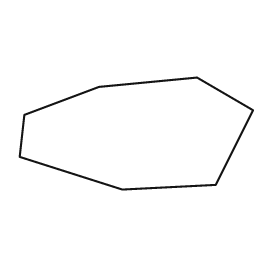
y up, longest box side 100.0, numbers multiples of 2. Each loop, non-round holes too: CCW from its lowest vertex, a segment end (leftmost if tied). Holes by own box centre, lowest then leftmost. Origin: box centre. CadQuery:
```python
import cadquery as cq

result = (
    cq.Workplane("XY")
    .moveTo(-6.0, -24.0)
    .lineTo(34.0, -22.0)
    .lineTo(50.0, 10.0)
    .lineTo(26.0, 24.0)
    .lineTo(-16.0, 20.0)
    .lineTo(-48.0, 8.0)
    .lineTo(-50.0, -10.0)
    .close()
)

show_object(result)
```